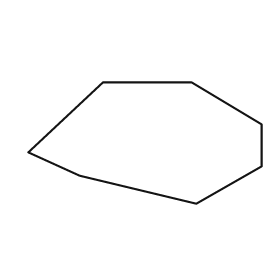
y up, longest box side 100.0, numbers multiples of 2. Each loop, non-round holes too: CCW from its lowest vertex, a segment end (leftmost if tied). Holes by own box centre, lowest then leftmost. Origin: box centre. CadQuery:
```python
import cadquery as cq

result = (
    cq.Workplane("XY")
    .moveTo(22.0, -26.0)
    .lineTo(50.0, -10.0)
    .lineTo(50.0, 8.0)
    .lineTo(20.0, 26.0)
    .lineTo(-18.0, 26.0)
    .lineTo(-50.0, -4.0)
    .lineTo(-28.0, -14.0)
    .close()
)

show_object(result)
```